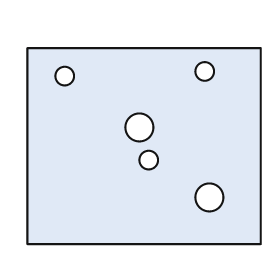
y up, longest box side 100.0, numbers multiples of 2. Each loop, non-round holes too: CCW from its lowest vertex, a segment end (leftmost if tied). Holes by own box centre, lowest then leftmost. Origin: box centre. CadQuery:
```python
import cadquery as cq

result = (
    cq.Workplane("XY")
    .moveTo(-50.0, -42.0)
    .lineTo(50.0, -42.0)
    .lineTo(50.0, 42.0)
    .lineTo(-50.0, 42.0)
    .close()
    .moveTo(28.0, -22.0)
    .circle(6.0)
    .moveTo(2.0, -6.0)
    .circle(4.0)
    .moveTo(-2.0, 8.0)
    .circle(6.0)
    .moveTo(-34.0, 30.0)
    .circle(4.0)
    .moveTo(26.0, 32.0)
    .circle(4.0)
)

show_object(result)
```